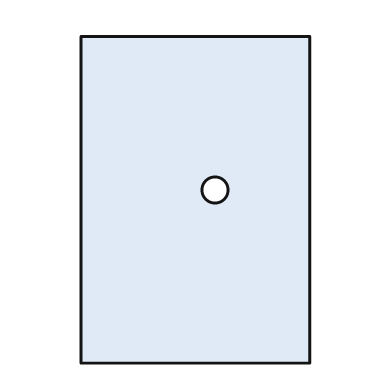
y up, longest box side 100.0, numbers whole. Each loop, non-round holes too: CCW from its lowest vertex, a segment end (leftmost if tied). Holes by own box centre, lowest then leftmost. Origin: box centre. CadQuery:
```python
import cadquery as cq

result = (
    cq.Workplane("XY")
    .moveTo(-35.0, -50.0)
    .lineTo(35.0, -50.0)
    .lineTo(35.0, 50.0)
    .lineTo(-35.0, 50.0)
    .close()
    .moveTo(6.0, 3.0)
    .circle(4.0)
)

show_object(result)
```